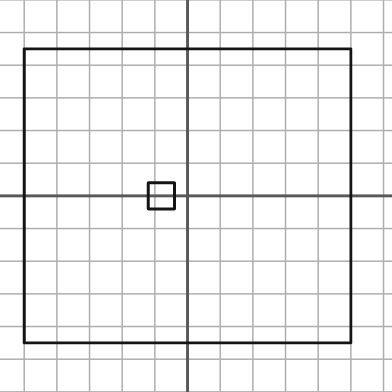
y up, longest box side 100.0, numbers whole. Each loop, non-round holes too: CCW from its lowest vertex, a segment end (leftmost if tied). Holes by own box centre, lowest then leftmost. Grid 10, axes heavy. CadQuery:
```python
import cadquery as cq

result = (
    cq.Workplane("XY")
    .moveTo(-50.0, -45.0)
    .lineTo(50.0, -45.0)
    .lineTo(50.0, 45.0)
    .lineTo(-50.0, 45.0)
    .close()
    .moveTo(-12.0, -4.0)
    .lineTo(-4.0, -4.0)
    .lineTo(-4.0, 4.0)
    .lineTo(-12.0, 4.0)
    .close()
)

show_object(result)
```